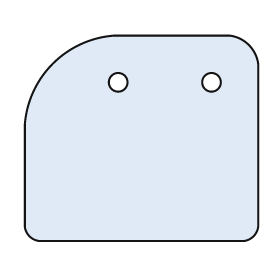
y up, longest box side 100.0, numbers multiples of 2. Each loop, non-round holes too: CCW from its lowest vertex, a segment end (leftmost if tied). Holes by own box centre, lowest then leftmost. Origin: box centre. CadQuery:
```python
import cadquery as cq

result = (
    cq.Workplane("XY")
    .moveTo(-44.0, -44.0)
    .lineTo(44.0, -44.0)
    .threePointArc((48.0, -42.0), (50.0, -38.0))
    .lineTo(50.0, 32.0)
    .threePointArc((46.0, 40.0), (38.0, 44.0))
    .lineTo(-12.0, 44.0)
    .threePointArc((-38.0, 32.0), (-50.0, 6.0))
    .lineTo(-50.0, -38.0)
    .threePointArc((-48.0, -42.0), (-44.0, -44.0))
    .close()
    .moveTo(-10.0, 24.0)
    .circle(4.0)
    .moveTo(30.0, 24.0)
    .circle(4.0)
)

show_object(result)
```